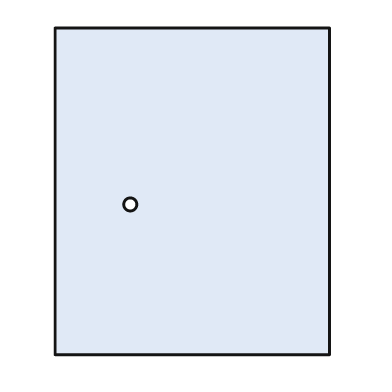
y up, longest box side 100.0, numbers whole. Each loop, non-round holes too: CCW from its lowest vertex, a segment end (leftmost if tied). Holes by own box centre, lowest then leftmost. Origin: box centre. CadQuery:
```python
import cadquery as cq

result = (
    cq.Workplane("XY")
    .moveTo(-42.0, -50.0)
    .lineTo(42.0, -50.0)
    .lineTo(42.0, 50.0)
    .lineTo(-42.0, 50.0)
    .close()
    .moveTo(-19.0, -4.0)
    .circle(2.0)
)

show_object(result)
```